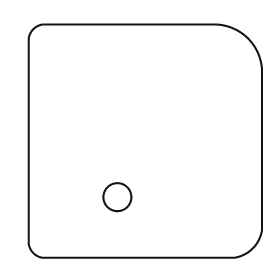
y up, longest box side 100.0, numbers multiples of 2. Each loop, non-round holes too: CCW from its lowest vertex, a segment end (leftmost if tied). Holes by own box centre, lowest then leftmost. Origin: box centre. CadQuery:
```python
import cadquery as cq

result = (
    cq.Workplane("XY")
    .moveTo(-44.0, -50.0)
    .lineTo(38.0, -50.0)
    .threePointArc((46.0, -46.0), (50.0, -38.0))
    .lineTo(50.0, 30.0)
    .threePointArc((44.0, 44.0), (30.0, 50.0))
    .lineTo(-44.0, 50.0)
    .threePointArc((-48.0, 48.0), (-50.0, 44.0))
    .lineTo(-50.0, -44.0)
    .threePointArc((-48.0, -48.0), (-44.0, -50.0))
    .close()
    .moveTo(-12.0, -24.0)
    .circle(6.0)
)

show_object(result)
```